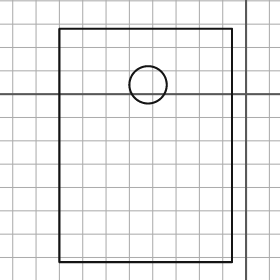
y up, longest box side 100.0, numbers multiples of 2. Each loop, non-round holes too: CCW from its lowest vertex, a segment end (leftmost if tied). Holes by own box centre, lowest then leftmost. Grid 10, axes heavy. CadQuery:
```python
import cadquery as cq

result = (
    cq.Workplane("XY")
    .moveTo(-80.0, -72.0)
    .lineTo(-6.0, -72.0)
    .lineTo(-6.0, 28.0)
    .lineTo(-80.0, 28.0)
    .close()
    .moveTo(-42.0, 4.0)
    .circle(8.0)
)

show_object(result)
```